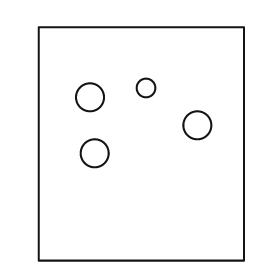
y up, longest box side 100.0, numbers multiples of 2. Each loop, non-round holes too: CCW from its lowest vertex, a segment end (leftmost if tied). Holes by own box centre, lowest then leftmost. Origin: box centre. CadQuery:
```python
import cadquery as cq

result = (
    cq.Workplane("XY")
    .moveTo(-44.0, -50.0)
    .lineTo(44.0, -50.0)
    .lineTo(44.0, 50.0)
    .lineTo(-44.0, 50.0)
    .close()
    .moveTo(-20.0, -4.0)
    .circle(6.0)
    .moveTo(24.0, 8.0)
    .circle(6.0)
    .moveTo(-22.0, 20.0)
    .circle(6.0)
    .moveTo(2.0, 24.0)
    .circle(4.0)
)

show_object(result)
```